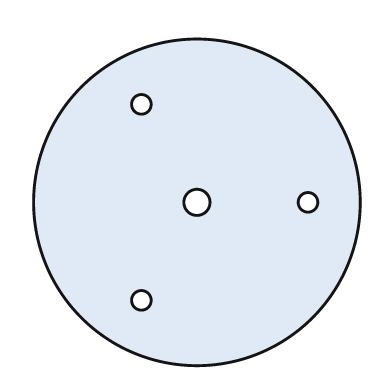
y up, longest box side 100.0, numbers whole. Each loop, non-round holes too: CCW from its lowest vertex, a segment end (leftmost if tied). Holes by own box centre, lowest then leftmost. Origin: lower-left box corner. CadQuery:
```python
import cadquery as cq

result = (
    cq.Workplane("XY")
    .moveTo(50.0, 50.0)
    .circle(50.0)
    .moveTo(33.0, 20.0)
    .circle(3.0)
    .moveTo(50.0, 50.0)
    .circle(4.0)
    .moveTo(84.0, 50.0)
    .circle(3.0)
    .moveTo(33.0, 80.0)
    .circle(3.0)
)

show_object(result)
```